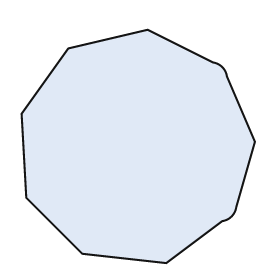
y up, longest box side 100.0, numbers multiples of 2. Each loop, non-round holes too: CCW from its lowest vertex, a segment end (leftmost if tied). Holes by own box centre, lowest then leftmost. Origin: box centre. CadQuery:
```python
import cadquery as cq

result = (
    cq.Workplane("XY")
    .moveTo(12.0, -50.0)
    .lineTo(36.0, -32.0)
    .threePointArc((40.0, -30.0), (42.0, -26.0))
    .lineTo(50.0, 2.0)
    .lineTo(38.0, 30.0)
    .threePointArc((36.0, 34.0), (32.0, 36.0))
    .lineTo(4.0, 50.0)
    .lineTo(-30.0, 42.0)
    .lineTo(-50.0, 14.0)
    .lineTo(-48.0, -22.0)
    .lineTo(-24.0, -46.0)
    .close()
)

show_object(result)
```